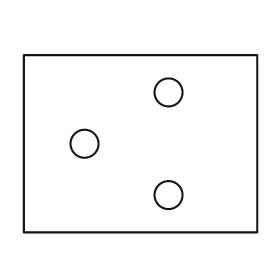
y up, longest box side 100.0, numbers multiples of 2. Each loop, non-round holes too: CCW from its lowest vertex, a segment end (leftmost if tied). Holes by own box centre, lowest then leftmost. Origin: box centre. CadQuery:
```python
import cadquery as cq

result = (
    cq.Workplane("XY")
    .moveTo(-50.0, -38.0)
    .lineTo(50.0, -38.0)
    .lineTo(50.0, 38.0)
    .lineTo(-50.0, 38.0)
    .close()
    .moveTo(12.0, -22.0)
    .circle(6.0)
    .moveTo(-24.0, 0.0)
    .circle(6.0)
    .moveTo(12.0, 22.0)
    .circle(6.0)
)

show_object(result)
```